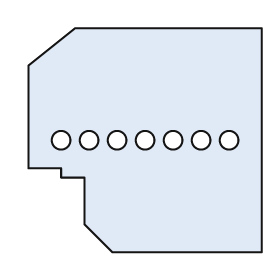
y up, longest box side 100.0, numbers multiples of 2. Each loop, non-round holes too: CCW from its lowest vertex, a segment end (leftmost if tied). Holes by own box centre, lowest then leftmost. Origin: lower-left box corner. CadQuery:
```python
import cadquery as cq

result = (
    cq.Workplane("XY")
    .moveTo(36.0, 0.0)
    .lineTo(100.0, 0.0)
    .lineTo(100.0, 96.0)
    .lineTo(20.0, 96.0)
    .lineTo(0.0, 80.0)
    .lineTo(0.0, 36.0)
    .lineTo(14.0, 36.0)
    .lineTo(14.0, 32.0)
    .lineTo(24.0, 32.0)
    .lineTo(24.0, 12.0)
    .close()
    .moveTo(14.0, 48.0)
    .circle(4.0)
    .moveTo(26.0, 48.0)
    .circle(4.0)
    .moveTo(38.0, 48.0)
    .circle(4.0)
    .moveTo(50.0, 48.0)
    .circle(4.0)
    .moveTo(62.0, 48.0)
    .circle(4.0)
    .moveTo(74.0, 48.0)
    .circle(4.0)
    .moveTo(86.0, 48.0)
    .circle(4.0)
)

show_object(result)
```